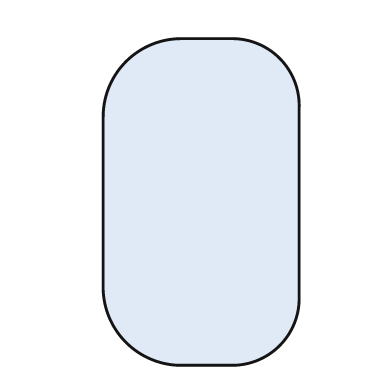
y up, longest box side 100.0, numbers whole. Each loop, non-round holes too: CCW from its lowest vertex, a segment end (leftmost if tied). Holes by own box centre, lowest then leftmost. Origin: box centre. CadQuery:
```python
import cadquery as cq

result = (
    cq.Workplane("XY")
    .moveTo(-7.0, -50.0)
    .lineTo(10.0, -50.0)
    .threePointArc((24.0, -44.0), (30.0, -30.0))
    .lineTo(30.0, 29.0)
    .threePointArc((24.0, 44.0), (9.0, 50.0))
    .lineTo(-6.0, 50.0)
    .threePointArc((-23.0, 43.0), (-30.0, 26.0))
    .lineTo(-30.0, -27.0)
    .threePointArc((-23.0, -43.0), (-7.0, -50.0))
    .close()
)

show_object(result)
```